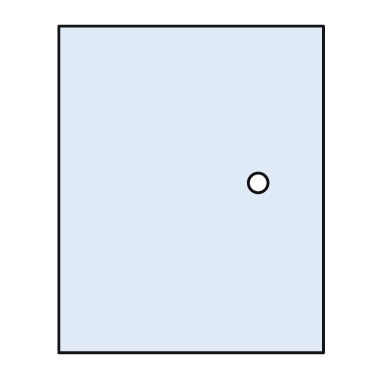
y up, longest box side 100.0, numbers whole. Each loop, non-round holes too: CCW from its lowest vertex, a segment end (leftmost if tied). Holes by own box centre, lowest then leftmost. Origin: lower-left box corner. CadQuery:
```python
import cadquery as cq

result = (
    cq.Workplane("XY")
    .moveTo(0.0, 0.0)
    .lineTo(81.0, 0.0)
    .lineTo(81.0, 100.0)
    .lineTo(0.0, 100.0)
    .close()
    .moveTo(61.0, 52.0)
    .circle(3.0)
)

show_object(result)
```